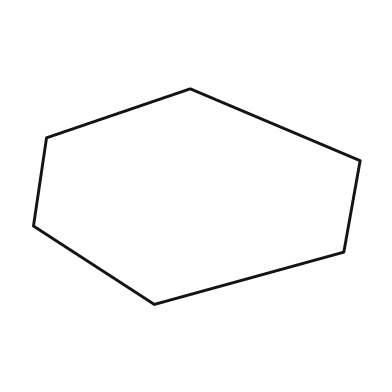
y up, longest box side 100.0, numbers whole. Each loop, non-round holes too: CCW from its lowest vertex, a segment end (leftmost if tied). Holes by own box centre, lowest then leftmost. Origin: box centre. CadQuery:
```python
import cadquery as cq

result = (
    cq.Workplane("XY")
    .moveTo(-13.0, -33.0)
    .lineTo(45.0, -17.0)
    .lineTo(50.0, 11.0)
    .lineTo(-2.0, 33.0)
    .lineTo(-46.0, 18.0)
    .lineTo(-50.0, -9.0)
    .close()
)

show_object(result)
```